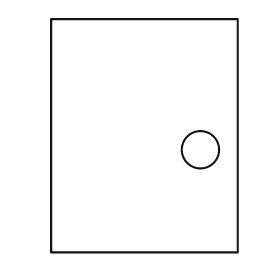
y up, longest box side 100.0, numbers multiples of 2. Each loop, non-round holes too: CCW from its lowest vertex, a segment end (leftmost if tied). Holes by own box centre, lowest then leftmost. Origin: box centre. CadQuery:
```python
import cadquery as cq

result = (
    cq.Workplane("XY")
    .moveTo(-40.0, -50.0)
    .lineTo(40.0, -50.0)
    .lineTo(40.0, 50.0)
    .lineTo(-40.0, 50.0)
    .close()
    .moveTo(24.0, -6.0)
    .circle(8.0)
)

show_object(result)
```